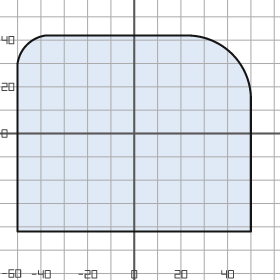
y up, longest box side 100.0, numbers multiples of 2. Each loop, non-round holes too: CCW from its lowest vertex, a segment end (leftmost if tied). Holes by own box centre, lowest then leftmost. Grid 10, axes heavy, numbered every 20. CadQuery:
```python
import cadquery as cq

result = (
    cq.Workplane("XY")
    .moveTo(-50.0, -42.0)
    .lineTo(50.0, -42.0)
    .lineTo(50.0, 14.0)
    .threePointArc((42.0, 34.0), (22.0, 42.0))
    .lineTo(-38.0, 42.0)
    .threePointArc((-46.0, 38.0), (-50.0, 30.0))
    .close()
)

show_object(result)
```